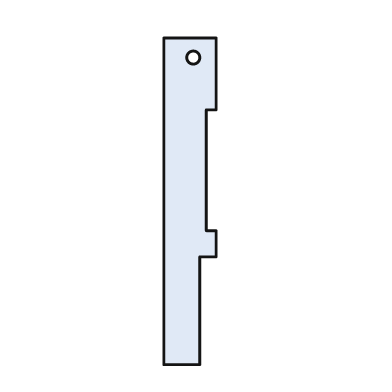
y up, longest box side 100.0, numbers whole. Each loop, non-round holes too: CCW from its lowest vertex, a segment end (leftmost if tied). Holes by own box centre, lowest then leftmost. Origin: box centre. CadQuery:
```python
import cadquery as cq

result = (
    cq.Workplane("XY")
    .moveTo(-8.0, -50.0)
    .lineTo(3.0, -50.0)
    .lineTo(3.0, -17.0)
    .lineTo(8.0, -17.0)
    .lineTo(8.0, -9.0)
    .lineTo(5.0, -9.0)
    .lineTo(5.0, 28.0)
    .lineTo(8.0, 28.0)
    .lineTo(8.0, 50.0)
    .lineTo(-8.0, 50.0)
    .close()
    .moveTo(1.0, 44.0)
    .circle(2.0)
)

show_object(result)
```